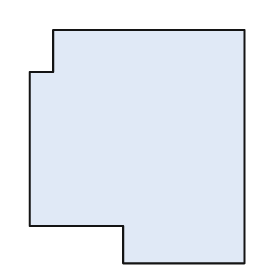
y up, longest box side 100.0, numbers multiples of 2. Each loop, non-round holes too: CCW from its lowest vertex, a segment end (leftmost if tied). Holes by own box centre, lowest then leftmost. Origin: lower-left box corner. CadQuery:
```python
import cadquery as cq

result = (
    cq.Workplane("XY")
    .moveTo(40.0, 0.0)
    .lineTo(92.0, 0.0)
    .lineTo(92.0, 100.0)
    .lineTo(10.0, 100.0)
    .lineTo(10.0, 82.0)
    .lineTo(0.0, 82.0)
    .lineTo(0.0, 16.0)
    .lineTo(40.0, 16.0)
    .close()
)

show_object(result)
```